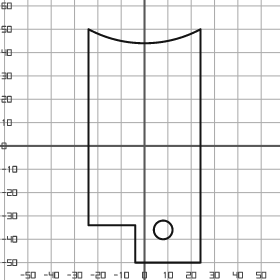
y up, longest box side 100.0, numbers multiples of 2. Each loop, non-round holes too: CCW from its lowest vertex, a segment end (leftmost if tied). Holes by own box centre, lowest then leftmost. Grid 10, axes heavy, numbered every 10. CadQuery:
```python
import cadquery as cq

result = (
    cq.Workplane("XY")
    .moveTo(-4.0, -50.0)
    .lineTo(24.0, -50.0)
    .lineTo(24.0, 50.0)
    .threePointArc((0.0, 44.0), (-24.0, 50.0))
    .lineTo(-24.0, -34.0)
    .lineTo(-4.0, -34.0)
    .close()
    .moveTo(8.0, -36.0)
    .circle(4.0)
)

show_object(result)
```